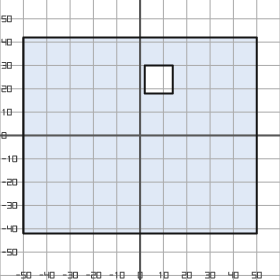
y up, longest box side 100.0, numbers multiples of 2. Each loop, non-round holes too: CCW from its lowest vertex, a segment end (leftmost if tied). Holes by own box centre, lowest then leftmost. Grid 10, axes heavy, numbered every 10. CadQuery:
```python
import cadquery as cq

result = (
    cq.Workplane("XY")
    .moveTo(-50.0, -42.0)
    .lineTo(50.0, -42.0)
    .lineTo(50.0, 42.0)
    .lineTo(-50.0, 42.0)
    .close()
    .moveTo(2.0, 18.0)
    .lineTo(14.0, 18.0)
    .lineTo(14.0, 30.0)
    .lineTo(2.0, 30.0)
    .close()
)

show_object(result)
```